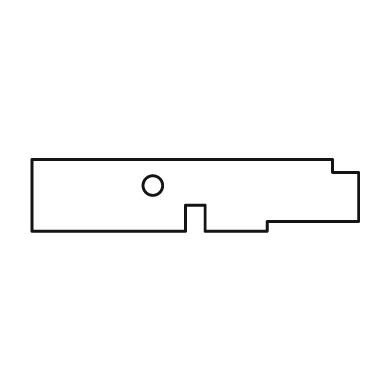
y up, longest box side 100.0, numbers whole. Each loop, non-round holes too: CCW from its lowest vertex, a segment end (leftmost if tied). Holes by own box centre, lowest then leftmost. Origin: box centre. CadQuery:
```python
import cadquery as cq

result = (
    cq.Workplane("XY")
    .moveTo(-50.0, -11.0)
    .lineTo(-3.0, -11.0)
    .lineTo(-3.0, -3.0)
    .lineTo(3.0, -3.0)
    .lineTo(3.0, -11.0)
    .lineTo(22.0, -11.0)
    .lineTo(22.0, -8.0)
    .lineTo(50.0, -8.0)
    .lineTo(50.0, 7.0)
    .lineTo(42.0, 7.0)
    .lineTo(42.0, 11.0)
    .lineTo(-50.0, 11.0)
    .close()
    .moveTo(-13.0, 3.0)
    .circle(3.0)
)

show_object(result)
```